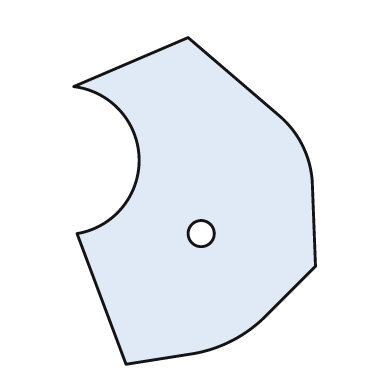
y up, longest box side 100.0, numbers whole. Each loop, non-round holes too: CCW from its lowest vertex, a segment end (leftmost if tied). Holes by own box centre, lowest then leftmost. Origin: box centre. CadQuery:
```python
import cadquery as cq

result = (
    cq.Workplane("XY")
    .moveTo(-21.0, -50.0)
    .lineTo(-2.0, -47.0)
    .threePointArc((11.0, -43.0), (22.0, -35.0))
    .lineTo(37.0, -20.0)
    .lineTo(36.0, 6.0)
    .threePointArc((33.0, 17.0), (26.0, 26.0))
    .lineTo(-2.0, 50.0)
    .lineTo(-37.0, 35.0)
    .threePointArc((-17.0, 13.0), (-36.0, -10.0))
    .close()
    .moveTo(2.0, -10.0)
    .circle(4.0)
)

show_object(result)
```